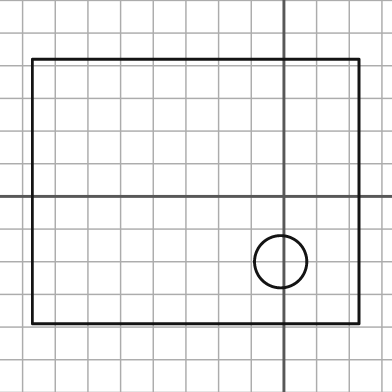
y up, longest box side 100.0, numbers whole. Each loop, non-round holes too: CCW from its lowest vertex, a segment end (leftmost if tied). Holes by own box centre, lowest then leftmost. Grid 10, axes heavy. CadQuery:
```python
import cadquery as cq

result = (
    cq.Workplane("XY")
    .moveTo(-77.0, -39.0)
    .lineTo(23.0, -39.0)
    .lineTo(23.0, 42.0)
    .lineTo(-77.0, 42.0)
    .close()
    .moveTo(-1.0, -20.0)
    .circle(8.0)
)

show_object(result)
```